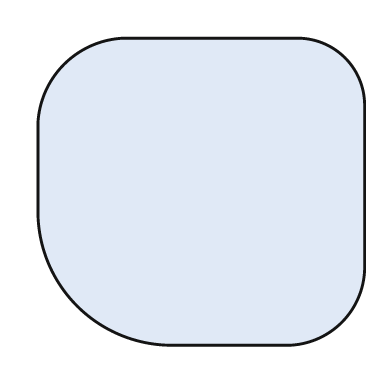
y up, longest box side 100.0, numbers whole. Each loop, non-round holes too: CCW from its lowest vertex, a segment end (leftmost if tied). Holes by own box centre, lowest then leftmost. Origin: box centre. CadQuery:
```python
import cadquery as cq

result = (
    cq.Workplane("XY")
    .moveTo(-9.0, -47.0)
    .lineTo(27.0, -47.0)
    .threePointArc((43.0, -40.0), (50.0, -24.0))
    .lineTo(50.0, 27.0)
    .threePointArc((44.0, 41.0), (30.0, 47.0))
    .lineTo(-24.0, 47.0)
    .threePointArc((-42.0, 39.0), (-50.0, 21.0))
    .lineTo(-50.0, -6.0)
    .threePointArc((-38.0, -35.0), (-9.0, -47.0))
    .close()
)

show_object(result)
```